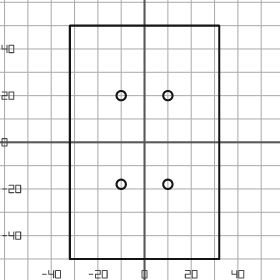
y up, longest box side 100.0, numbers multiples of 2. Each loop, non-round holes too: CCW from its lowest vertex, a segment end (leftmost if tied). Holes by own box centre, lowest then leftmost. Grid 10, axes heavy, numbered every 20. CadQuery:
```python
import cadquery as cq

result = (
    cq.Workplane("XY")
    .moveTo(-32.0, -50.0)
    .lineTo(32.0, -50.0)
    .lineTo(32.0, 50.0)
    .lineTo(-32.0, 50.0)
    .close()
    .moveTo(-10.0, -18.0)
    .circle(2.0)
    .moveTo(10.0, -18.0)
    .circle(2.0)
    .moveTo(-10.0, 20.0)
    .circle(2.0)
    .moveTo(10.0, 20.0)
    .circle(2.0)
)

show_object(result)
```